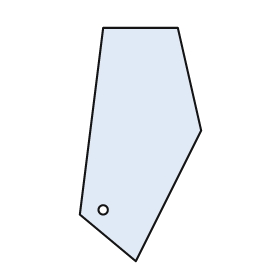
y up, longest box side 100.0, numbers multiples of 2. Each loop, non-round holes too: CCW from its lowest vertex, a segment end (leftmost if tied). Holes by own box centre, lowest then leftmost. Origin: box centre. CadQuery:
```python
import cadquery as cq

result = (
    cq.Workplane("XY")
    .moveTo(-2.0, -50.0)
    .lineTo(26.0, 6.0)
    .lineTo(16.0, 50.0)
    .lineTo(-16.0, 50.0)
    .lineTo(-26.0, -30.0)
    .close()
    .moveTo(-16.0, -28.0)
    .circle(2.0)
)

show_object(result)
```